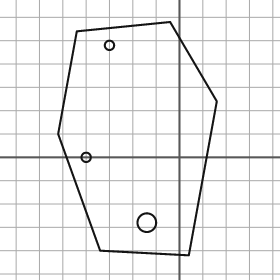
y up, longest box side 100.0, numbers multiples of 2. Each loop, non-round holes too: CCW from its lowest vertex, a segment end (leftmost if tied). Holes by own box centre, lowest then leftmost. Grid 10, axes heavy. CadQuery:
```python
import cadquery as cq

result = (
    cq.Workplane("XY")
    .moveTo(4.0, -42.0)
    .lineTo(16.0, 24.0)
    .lineTo(-4.0, 58.0)
    .lineTo(-44.0, 54.0)
    .lineTo(-52.0, 10.0)
    .lineTo(-34.0, -40.0)
    .close()
    .moveTo(-14.0, -28.0)
    .circle(4.0)
    .moveTo(-40.0, 0.0)
    .circle(2.0)
    .moveTo(-30.0, 48.0)
    .circle(2.0)
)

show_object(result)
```